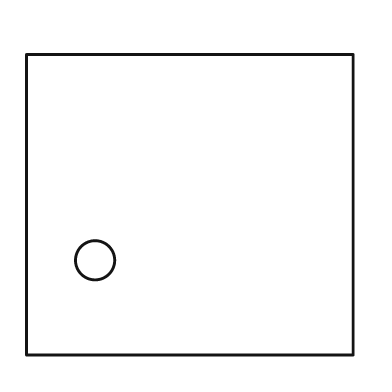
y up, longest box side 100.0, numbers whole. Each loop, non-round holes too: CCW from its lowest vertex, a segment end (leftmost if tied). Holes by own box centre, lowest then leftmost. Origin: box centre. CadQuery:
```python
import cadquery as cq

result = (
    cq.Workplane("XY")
    .moveTo(-50.0, -46.0)
    .lineTo(50.0, -46.0)
    .lineTo(50.0, 46.0)
    .lineTo(-50.0, 46.0)
    .close()
    .moveTo(-29.0, -17.0)
    .circle(6.0)
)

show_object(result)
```